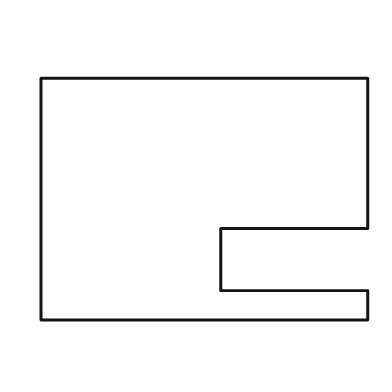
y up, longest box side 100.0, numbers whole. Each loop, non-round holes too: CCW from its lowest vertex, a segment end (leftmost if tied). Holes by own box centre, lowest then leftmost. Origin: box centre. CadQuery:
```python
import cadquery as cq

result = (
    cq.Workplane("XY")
    .moveTo(-50.0, -37.0)
    .lineTo(50.0, -37.0)
    .lineTo(50.0, -28.0)
    .lineTo(5.0, -28.0)
    .lineTo(5.0, -9.0)
    .lineTo(50.0, -9.0)
    .lineTo(50.0, 37.0)
    .lineTo(-50.0, 37.0)
    .close()
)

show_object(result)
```